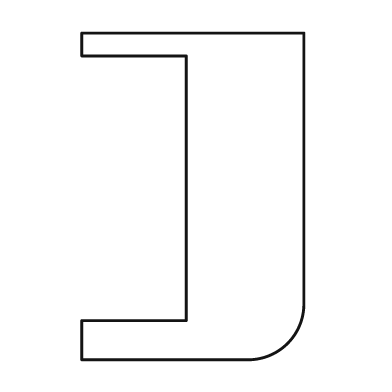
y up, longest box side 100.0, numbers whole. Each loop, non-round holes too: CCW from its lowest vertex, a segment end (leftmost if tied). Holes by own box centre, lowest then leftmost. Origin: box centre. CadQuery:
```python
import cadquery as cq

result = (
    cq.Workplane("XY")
    .moveTo(-34.0, -50.0)
    .lineTo(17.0, -50.0)
    .threePointArc((29.0, -45.0), (34.0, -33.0))
    .lineTo(34.0, 50.0)
    .lineTo(-34.0, 50.0)
    .lineTo(-34.0, 43.0)
    .lineTo(-2.0, 43.0)
    .lineTo(-2.0, -38.0)
    .lineTo(-34.0, -38.0)
    .close()
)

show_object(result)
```